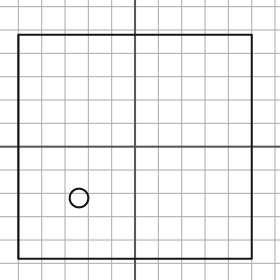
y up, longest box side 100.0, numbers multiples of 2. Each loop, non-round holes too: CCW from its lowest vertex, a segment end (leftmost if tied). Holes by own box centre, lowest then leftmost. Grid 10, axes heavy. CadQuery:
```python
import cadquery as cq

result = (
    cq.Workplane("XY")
    .moveTo(-50.0, -48.0)
    .lineTo(50.0, -48.0)
    .lineTo(50.0, 48.0)
    .lineTo(-50.0, 48.0)
    .close()
    .moveTo(-24.0, -22.0)
    .circle(4.0)
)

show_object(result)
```